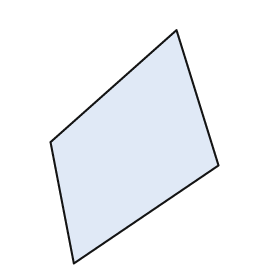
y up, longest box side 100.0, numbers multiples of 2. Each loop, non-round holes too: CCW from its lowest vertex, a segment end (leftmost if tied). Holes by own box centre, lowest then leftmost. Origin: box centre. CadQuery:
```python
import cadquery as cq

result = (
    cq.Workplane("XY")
    .moveTo(-26.0, -50.0)
    .lineTo(36.0, -8.0)
    .lineTo(18.0, 50.0)
    .lineTo(-36.0, 2.0)
    .close()
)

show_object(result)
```